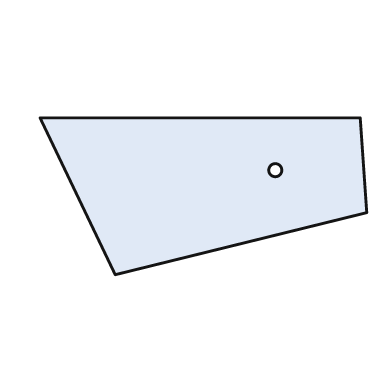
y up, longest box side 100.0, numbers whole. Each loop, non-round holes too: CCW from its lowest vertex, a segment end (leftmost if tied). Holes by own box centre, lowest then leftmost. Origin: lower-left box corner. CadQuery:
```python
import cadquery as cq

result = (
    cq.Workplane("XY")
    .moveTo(23.0, 0.0)
    .lineTo(100.0, 19.0)
    .lineTo(98.0, 48.0)
    .lineTo(0.0, 48.0)
    .close()
    .moveTo(72.0, 32.0)
    .circle(2.0)
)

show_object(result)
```